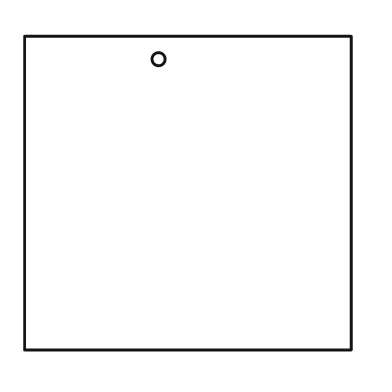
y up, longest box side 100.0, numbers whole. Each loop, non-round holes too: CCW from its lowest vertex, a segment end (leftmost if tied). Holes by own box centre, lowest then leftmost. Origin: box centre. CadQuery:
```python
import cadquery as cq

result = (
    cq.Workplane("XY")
    .moveTo(-50.0, -48.0)
    .lineTo(50.0, -48.0)
    .lineTo(50.0, 48.0)
    .lineTo(-50.0, 48.0)
    .close()
    .moveTo(-9.0, 41.0)
    .circle(2.0)
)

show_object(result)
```